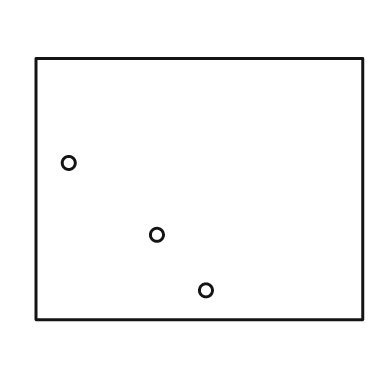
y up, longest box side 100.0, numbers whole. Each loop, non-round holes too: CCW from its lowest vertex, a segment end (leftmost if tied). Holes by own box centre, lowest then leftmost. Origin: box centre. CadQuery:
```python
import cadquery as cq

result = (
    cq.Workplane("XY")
    .moveTo(-50.0, -40.0)
    .lineTo(50.0, -40.0)
    .lineTo(50.0, 40.0)
    .lineTo(-50.0, 40.0)
    .close()
    .moveTo(2.0, -31.0)
    .circle(2.0)
    .moveTo(-13.0, -14.0)
    .circle(2.0)
    .moveTo(-40.0, 8.0)
    .circle(2.0)
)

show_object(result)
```